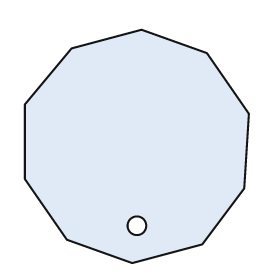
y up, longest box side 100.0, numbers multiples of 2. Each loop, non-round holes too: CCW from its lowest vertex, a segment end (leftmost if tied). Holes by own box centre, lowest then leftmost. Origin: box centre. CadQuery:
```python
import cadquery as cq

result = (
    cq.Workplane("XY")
    .moveTo(-2.0, -50.0)
    .lineTo(28.0, -42.0)
    .lineTo(46.0, -18.0)
    .lineTo(48.0, 14.0)
    .lineTo(30.0, 40.0)
    .lineTo(2.0, 50.0)
    .lineTo(-28.0, 42.0)
    .lineTo(-48.0, 18.0)
    .lineTo(-48.0, -14.0)
    .lineTo(-30.0, -40.0)
    .close()
    .moveTo(0.0, -34.0)
    .circle(4.0)
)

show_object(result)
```